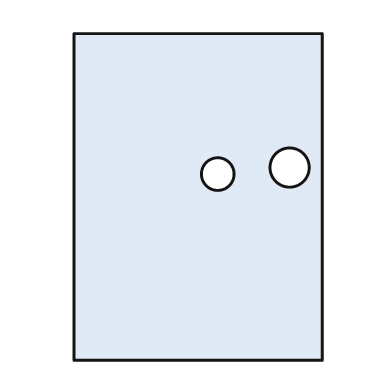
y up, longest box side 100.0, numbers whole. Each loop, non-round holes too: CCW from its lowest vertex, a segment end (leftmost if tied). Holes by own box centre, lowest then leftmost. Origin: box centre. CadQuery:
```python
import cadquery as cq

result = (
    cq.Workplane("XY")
    .moveTo(-38.0, -50.0)
    .lineTo(38.0, -50.0)
    .lineTo(38.0, 50.0)
    .lineTo(-38.0, 50.0)
    .close()
    .moveTo(6.0, 7.0)
    .circle(5.0)
    .moveTo(28.0, 9.0)
    .circle(6.0)
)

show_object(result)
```